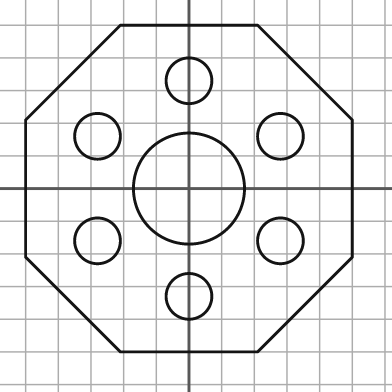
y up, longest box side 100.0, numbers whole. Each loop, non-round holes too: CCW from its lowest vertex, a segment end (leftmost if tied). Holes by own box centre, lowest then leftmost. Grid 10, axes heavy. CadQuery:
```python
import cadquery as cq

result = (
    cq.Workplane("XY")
    .moveTo(-21.0, -50.0)
    .lineTo(21.0, -50.0)
    .lineTo(50.0, -21.0)
    .lineTo(50.0, 21.0)
    .lineTo(21.0, 50.0)
    .lineTo(-21.0, 50.0)
    .lineTo(-50.0, 21.0)
    .lineTo(-50.0, -21.0)
    .close()
    .moveTo(0.0, -33.0)
    .circle(7.0)
    .moveTo(-28.0, -16.0)
    .circle(7.0)
    .moveTo(28.0, -16.0)
    .circle(7.0)
    .moveTo(0.0, 0.0)
    .circle(17.0)
    .moveTo(-28.0, 16.0)
    .circle(7.0)
    .moveTo(28.0, 16.0)
    .circle(7.0)
    .moveTo(0.0, 33.0)
    .circle(7.0)
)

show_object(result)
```